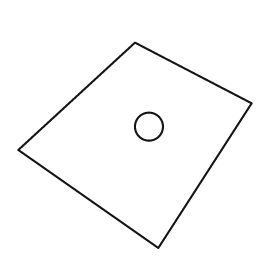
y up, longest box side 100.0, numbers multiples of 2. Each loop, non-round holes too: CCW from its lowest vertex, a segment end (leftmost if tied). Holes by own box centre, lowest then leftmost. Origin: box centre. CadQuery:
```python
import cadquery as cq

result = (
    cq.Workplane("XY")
    .moveTo(10.0, -44.0)
    .lineTo(50.0, 18.0)
    .lineTo(0.0, 44.0)
    .lineTo(-50.0, -2.0)
    .close()
    .moveTo(6.0, 8.0)
    .circle(6.0)
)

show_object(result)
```